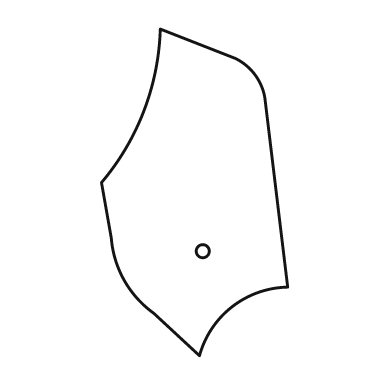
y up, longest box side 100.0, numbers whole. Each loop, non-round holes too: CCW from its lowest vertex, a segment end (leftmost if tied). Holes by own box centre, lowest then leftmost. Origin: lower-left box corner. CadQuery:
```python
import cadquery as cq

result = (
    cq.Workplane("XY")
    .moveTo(30.0, 0.0)
    .threePointArc((40.0, 15.0), (57.0, 21.0))
    .lineTo(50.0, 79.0)
    .threePointArc((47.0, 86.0), (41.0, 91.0))
    .lineTo(18.0, 100.0)
    .threePointArc((13.0, 75.0), (0.0, 53.0))
    .lineTo(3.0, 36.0)
    .threePointArc((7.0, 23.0), (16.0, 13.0))
    .close()
    .moveTo(31.0, 32.0)
    .circle(2.0)
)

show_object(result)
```